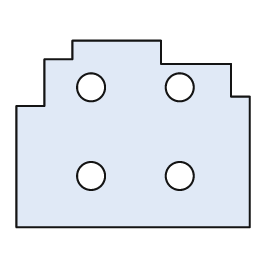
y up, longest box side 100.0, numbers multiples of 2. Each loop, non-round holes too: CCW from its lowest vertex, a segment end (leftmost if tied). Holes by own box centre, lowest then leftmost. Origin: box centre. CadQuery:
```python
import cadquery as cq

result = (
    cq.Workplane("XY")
    .moveTo(-50.0, -40.0)
    .lineTo(50.0, -40.0)
    .lineTo(50.0, 16.0)
    .lineTo(42.0, 16.0)
    .lineTo(42.0, 30.0)
    .lineTo(12.0, 30.0)
    .lineTo(12.0, 40.0)
    .lineTo(-26.0, 40.0)
    .lineTo(-26.0, 32.0)
    .lineTo(-38.0, 32.0)
    .lineTo(-38.0, 12.0)
    .lineTo(-50.0, 12.0)
    .close()
    .moveTo(-18.0, -18.0)
    .circle(6.0)
    .moveTo(20.0, -18.0)
    .circle(6.0)
    .moveTo(-18.0, 20.0)
    .circle(6.0)
    .moveTo(20.0, 20.0)
    .circle(6.0)
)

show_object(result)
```